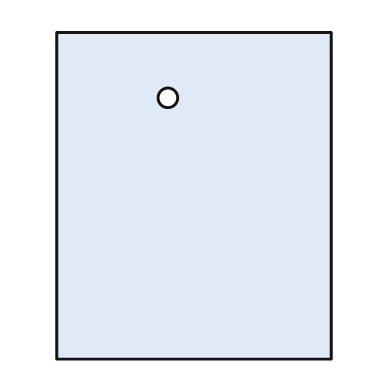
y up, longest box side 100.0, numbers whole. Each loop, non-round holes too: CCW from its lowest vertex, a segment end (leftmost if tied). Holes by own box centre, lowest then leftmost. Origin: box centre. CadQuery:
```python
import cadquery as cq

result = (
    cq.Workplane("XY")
    .moveTo(-42.0, -50.0)
    .lineTo(42.0, -50.0)
    .lineTo(42.0, 50.0)
    .lineTo(-42.0, 50.0)
    .close()
    .moveTo(-8.0, 30.0)
    .circle(3.0)
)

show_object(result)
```